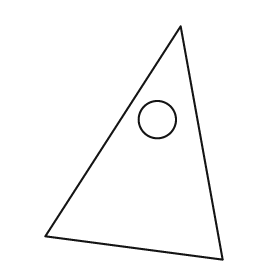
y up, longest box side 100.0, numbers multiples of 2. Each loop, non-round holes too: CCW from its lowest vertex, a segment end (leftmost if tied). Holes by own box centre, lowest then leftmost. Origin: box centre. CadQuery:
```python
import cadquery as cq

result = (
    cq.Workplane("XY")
    .moveTo(38.0, -50.0)
    .lineTo(20.0, 50.0)
    .lineTo(-38.0, -40.0)
    .close()
    .moveTo(10.0, 10.0)
    .circle(8.0)
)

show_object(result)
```